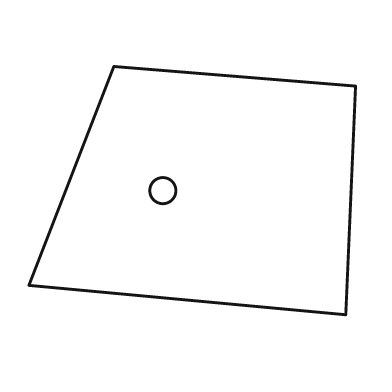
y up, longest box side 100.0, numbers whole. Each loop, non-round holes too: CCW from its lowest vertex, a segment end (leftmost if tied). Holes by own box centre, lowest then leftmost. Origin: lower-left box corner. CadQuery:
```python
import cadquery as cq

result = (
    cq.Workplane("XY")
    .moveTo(97.0, 0.0)
    .lineTo(100.0, 70.0)
    .lineTo(26.0, 76.0)
    .lineTo(0.0, 9.0)
    .close()
    .moveTo(41.0, 38.0)
    .circle(4.0)
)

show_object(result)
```